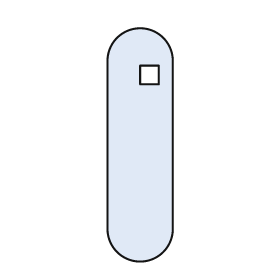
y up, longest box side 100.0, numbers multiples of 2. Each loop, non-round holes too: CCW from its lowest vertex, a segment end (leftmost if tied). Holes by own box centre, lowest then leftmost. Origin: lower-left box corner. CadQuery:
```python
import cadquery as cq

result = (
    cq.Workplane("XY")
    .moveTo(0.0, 14.0)
    .threePointArc((14.0, 0.0), (28.0, 14.0))
    .lineTo(28.0, 86.0)
    .threePointArc((14.0, 100.0), (0.0, 86.0))
    .close()
    .moveTo(14.0, 76.0)
    .lineTo(22.0, 76.0)
    .lineTo(22.0, 84.0)
    .lineTo(14.0, 84.0)
    .close()
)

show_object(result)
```